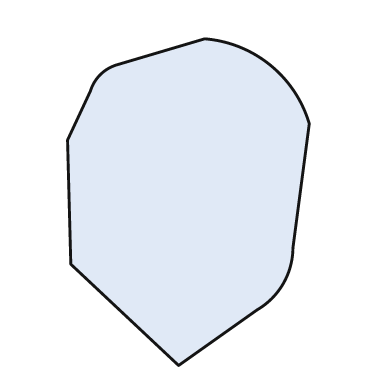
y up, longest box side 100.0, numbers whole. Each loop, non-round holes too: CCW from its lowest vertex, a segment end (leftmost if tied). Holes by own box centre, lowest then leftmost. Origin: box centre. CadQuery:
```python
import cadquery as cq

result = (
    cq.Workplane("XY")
    .moveTo(-3.0, -50.0)
    .lineTo(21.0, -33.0)
    .threePointArc((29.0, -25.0), (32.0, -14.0))
    .lineTo(37.0, 24.0)
    .threePointArc((25.0, 42.0), (5.0, 50.0))
    .lineTo(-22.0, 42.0)
    .threePointArc((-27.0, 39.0), (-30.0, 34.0))
    .lineTo(-37.0, 19.0)
    .lineTo(-36.0, -19.0)
    .close()
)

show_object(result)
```